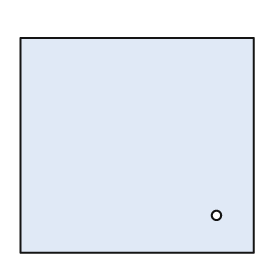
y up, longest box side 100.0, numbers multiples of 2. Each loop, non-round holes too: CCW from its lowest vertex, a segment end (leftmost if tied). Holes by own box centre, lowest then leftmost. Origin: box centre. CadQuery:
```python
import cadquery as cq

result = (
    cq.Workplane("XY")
    .moveTo(-50.0, -46.0)
    .lineTo(50.0, -46.0)
    .lineTo(50.0, 46.0)
    .lineTo(-50.0, 46.0)
    .close()
    .moveTo(34.0, -30.0)
    .circle(2.0)
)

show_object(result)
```